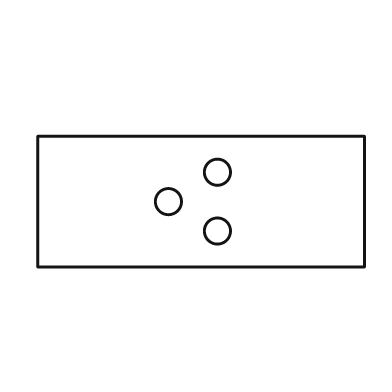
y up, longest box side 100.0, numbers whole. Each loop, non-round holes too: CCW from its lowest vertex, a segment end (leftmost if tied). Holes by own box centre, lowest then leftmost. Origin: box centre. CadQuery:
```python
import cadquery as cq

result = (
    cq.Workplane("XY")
    .moveTo(-50.0, -20.0)
    .lineTo(50.0, -20.0)
    .lineTo(50.0, 20.0)
    .lineTo(-50.0, 20.0)
    .close()
    .moveTo(5.0, -9.0)
    .circle(4.0)
    .moveTo(-10.0, 0.0)
    .circle(4.0)
    .moveTo(5.0, 9.0)
    .circle(4.0)
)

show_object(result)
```